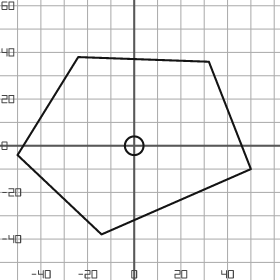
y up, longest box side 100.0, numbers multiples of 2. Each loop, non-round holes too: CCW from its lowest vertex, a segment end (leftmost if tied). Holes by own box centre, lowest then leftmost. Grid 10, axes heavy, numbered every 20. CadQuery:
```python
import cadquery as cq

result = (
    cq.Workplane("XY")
    .moveTo(-14.0, -38.0)
    .lineTo(50.0, -10.0)
    .lineTo(32.0, 36.0)
    .lineTo(-24.0, 38.0)
    .lineTo(-50.0, -4.0)
    .close()
    .moveTo(0.0, 0.0)
    .circle(4.0)
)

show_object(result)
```